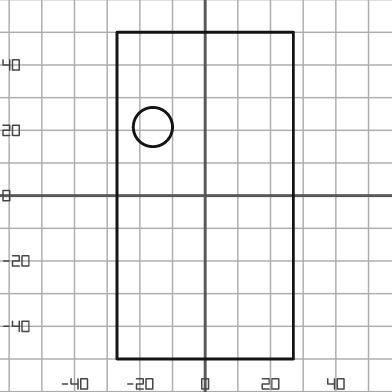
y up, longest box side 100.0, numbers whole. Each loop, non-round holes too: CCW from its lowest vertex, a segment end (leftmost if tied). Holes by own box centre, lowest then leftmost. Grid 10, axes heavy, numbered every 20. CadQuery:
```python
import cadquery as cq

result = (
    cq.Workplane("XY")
    .moveTo(-27.0, -50.0)
    .lineTo(27.0, -50.0)
    .lineTo(27.0, 50.0)
    .lineTo(-27.0, 50.0)
    .close()
    .moveTo(-16.0, 21.0)
    .circle(6.0)
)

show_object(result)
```